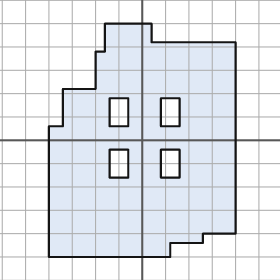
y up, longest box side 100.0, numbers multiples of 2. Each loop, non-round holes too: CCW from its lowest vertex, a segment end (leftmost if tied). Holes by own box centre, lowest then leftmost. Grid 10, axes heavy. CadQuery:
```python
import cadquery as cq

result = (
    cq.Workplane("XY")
    .moveTo(-40.0, -50.0)
    .lineTo(12.0, -50.0)
    .lineTo(12.0, -44.0)
    .lineTo(26.0, -44.0)
    .lineTo(26.0, -40.0)
    .lineTo(40.0, -40.0)
    .lineTo(40.0, 42.0)
    .lineTo(4.0, 42.0)
    .lineTo(4.0, 50.0)
    .lineTo(-16.0, 50.0)
    .lineTo(-16.0, 38.0)
    .lineTo(-20.0, 38.0)
    .lineTo(-20.0, 22.0)
    .lineTo(-34.0, 22.0)
    .lineTo(-34.0, 6.0)
    .lineTo(-40.0, 6.0)
    .close()
    .moveTo(-14.0, -16.0)
    .lineTo(-6.0, -16.0)
    .lineTo(-6.0, -4.0)
    .lineTo(-14.0, -4.0)
    .close()
    .moveTo(8.0, -16.0)
    .lineTo(16.0, -16.0)
    .lineTo(16.0, -4.0)
    .lineTo(8.0, -4.0)
    .close()
    .moveTo(-14.0, 6.0)
    .lineTo(-6.0, 6.0)
    .lineTo(-6.0, 18.0)
    .lineTo(-14.0, 18.0)
    .close()
    .moveTo(8.0, 6.0)
    .lineTo(16.0, 6.0)
    .lineTo(16.0, 18.0)
    .lineTo(8.0, 18.0)
    .close()
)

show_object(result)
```